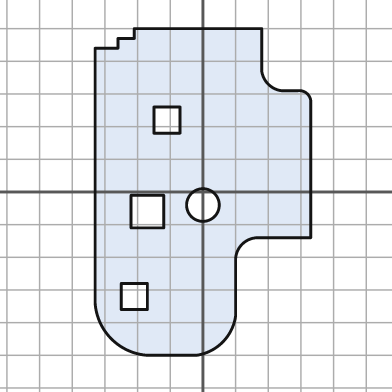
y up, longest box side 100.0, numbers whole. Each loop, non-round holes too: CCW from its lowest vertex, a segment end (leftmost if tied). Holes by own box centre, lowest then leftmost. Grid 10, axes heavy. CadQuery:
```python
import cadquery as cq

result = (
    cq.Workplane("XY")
    .moveTo(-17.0, -50.0)
    .lineTo(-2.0, -50.0)
    .threePointArc((6.0, -46.0), (10.0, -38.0))
    .lineTo(10.0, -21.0)
    .threePointArc((12.0, -16.0), (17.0, -14.0))
    .lineTo(33.0, -14.0)
    .lineTo(33.0, 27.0)
    .threePointArc((32.0, 30.0), (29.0, 31.0))
    .lineTo(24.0, 31.0)
    .threePointArc((20.0, 33.0), (18.0, 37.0))
    .lineTo(18.0, 50.0)
    .lineTo(-21.0, 50.0)
    .lineTo(-21.0, 47.0)
    .lineTo(-26.0, 47.0)
    .lineTo(-26.0, 44.0)
    .lineTo(-33.0, 44.0)
    .lineTo(-33.0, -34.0)
    .threePointArc((-28.0, -45.0), (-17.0, -50.0))
    .close()
    .moveTo(-25.0, -36.0)
    .lineTo(-17.0, -36.0)
    .lineTo(-17.0, -28.0)
    .lineTo(-25.0, -28.0)
    .close()
    .moveTo(-22.0, -11.0)
    .lineTo(-12.0, -11.0)
    .lineTo(-12.0, -1.0)
    .lineTo(-22.0, -1.0)
    .close()
    .moveTo(0.0, -4.0)
    .circle(5.0)
    .moveTo(-15.0, 18.0)
    .lineTo(-7.0, 18.0)
    .lineTo(-7.0, 26.0)
    .lineTo(-15.0, 26.0)
    .close()
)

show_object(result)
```